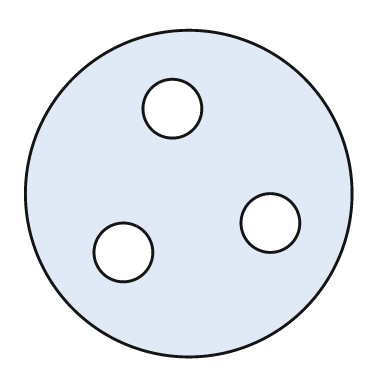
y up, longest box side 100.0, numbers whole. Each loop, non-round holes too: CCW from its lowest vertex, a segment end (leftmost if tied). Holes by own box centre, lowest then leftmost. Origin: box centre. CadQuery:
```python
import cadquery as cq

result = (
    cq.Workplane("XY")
    .moveTo(0.0, 0.0)
    .circle(50.0)
    .moveTo(-20.0, -18.0)
    .circle(9.0)
    .moveTo(25.0, -9.0)
    .circle(9.0)
    .moveTo(-5.0, 26.0)
    .circle(9.0)
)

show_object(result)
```